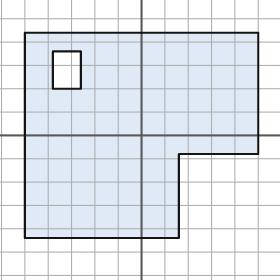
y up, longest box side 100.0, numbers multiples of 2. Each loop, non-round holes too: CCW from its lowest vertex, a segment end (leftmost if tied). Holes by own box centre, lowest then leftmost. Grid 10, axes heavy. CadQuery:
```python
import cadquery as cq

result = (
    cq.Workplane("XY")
    .moveTo(-50.0, -44.0)
    .lineTo(16.0, -44.0)
    .lineTo(16.0, -8.0)
    .lineTo(50.0, -8.0)
    .lineTo(50.0, 44.0)
    .lineTo(-50.0, 44.0)
    .close()
    .moveTo(-38.0, 20.0)
    .lineTo(-26.0, 20.0)
    .lineTo(-26.0, 36.0)
    .lineTo(-38.0, 36.0)
    .close()
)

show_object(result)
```